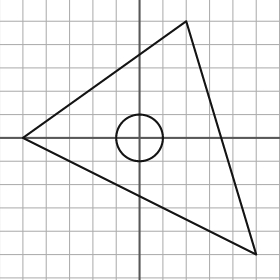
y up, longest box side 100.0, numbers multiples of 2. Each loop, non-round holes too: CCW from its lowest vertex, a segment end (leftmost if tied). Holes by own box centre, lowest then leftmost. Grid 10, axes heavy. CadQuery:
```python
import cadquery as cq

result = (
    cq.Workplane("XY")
    .moveTo(50.0, -50.0)
    .lineTo(20.0, 50.0)
    .lineTo(-50.0, 0.0)
    .close()
    .moveTo(0.0, 0.0)
    .circle(10.0)
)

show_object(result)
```